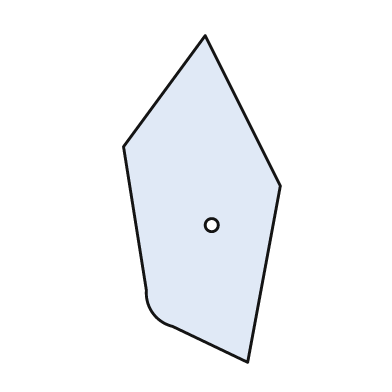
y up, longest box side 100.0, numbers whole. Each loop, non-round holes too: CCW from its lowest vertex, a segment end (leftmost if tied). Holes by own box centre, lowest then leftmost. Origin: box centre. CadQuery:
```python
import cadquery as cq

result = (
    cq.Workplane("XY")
    .moveTo(14.0, -50.0)
    .lineTo(24.0, 4.0)
    .lineTo(1.0, 50.0)
    .lineTo(-24.0, 16.0)
    .lineTo(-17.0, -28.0)
    .threePointArc((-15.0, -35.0), (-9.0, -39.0))
    .close()
    .moveTo(3.0, -8.0)
    .circle(2.0)
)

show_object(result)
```